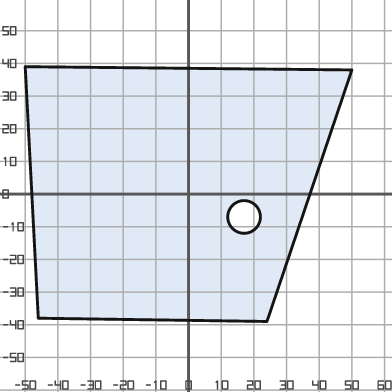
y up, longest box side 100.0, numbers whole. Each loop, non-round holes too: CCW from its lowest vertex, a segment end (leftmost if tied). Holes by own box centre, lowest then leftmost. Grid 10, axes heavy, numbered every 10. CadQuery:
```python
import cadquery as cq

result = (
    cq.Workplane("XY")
    .moveTo(24.0, -39.0)
    .lineTo(50.0, 38.0)
    .lineTo(-50.0, 39.0)
    .lineTo(-46.0, -38.0)
    .close()
    .moveTo(17.0, -7.0)
    .circle(5.0)
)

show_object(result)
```